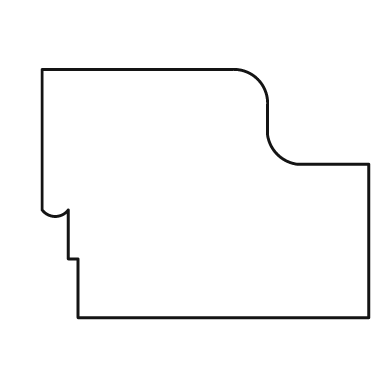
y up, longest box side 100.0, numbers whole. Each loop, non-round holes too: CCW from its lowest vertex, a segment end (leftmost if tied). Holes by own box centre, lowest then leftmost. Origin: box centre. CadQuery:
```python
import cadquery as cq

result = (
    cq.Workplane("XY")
    .moveTo(-39.0, -38.0)
    .lineTo(50.0, -38.0)
    .lineTo(50.0, 9.0)
    .lineTo(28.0, 9.0)
    .threePointArc((22.0, 12.0), (19.0, 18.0))
    .lineTo(19.0, 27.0)
    .threePointArc((16.0, 35.0), (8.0, 38.0))
    .lineTo(-50.0, 38.0)
    .lineTo(-50.0, -5.0)
    .threePointArc((-46.0, -7.0), (-42.0, -5.0))
    .lineTo(-42.0, -20.0)
    .lineTo(-39.0, -20.0)
    .close()
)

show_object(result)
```